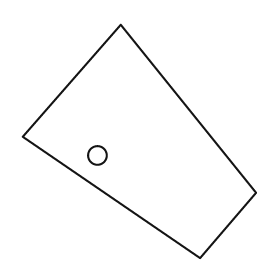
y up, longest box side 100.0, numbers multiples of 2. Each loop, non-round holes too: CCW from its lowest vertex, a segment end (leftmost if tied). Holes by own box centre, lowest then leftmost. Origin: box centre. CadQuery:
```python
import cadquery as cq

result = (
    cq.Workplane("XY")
    .moveTo(26.0, -50.0)
    .lineTo(50.0, -22.0)
    .lineTo(-8.0, 50.0)
    .lineTo(-50.0, 2.0)
    .close()
    .moveTo(-18.0, -6.0)
    .circle(4.0)
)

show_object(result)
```